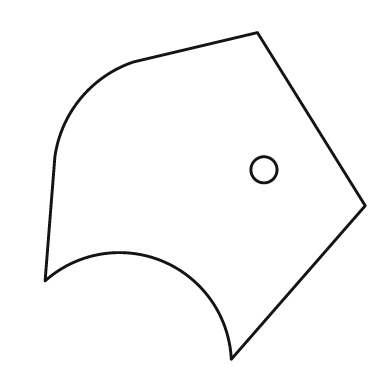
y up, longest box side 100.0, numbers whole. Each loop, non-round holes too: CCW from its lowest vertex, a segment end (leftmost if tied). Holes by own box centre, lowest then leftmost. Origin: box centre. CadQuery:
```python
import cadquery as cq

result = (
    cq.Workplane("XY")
    .moveTo(8.0, -50.0)
    .lineTo(49.0, -3.0)
    .lineTo(16.0, 50.0)
    .lineTo(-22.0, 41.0)
    .threePointArc((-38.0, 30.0), (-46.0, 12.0))
    .lineTo(-49.0, -26.0)
    .threePointArc((-13.0, -20.0), (8.0, -50.0))
    .close()
    .moveTo(18.0, 8.0)
    .circle(4.0)
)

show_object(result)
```